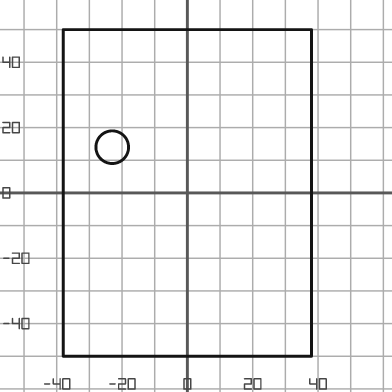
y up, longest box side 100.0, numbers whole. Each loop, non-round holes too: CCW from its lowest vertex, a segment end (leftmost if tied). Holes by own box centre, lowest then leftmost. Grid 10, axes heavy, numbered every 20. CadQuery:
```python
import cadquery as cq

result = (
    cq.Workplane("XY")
    .moveTo(-38.0, -50.0)
    .lineTo(38.0, -50.0)
    .lineTo(38.0, 50.0)
    .lineTo(-38.0, 50.0)
    .close()
    .moveTo(-23.0, 14.0)
    .circle(5.0)
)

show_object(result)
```